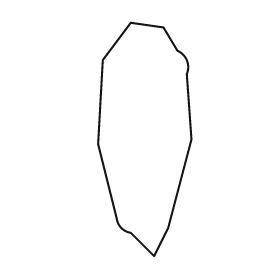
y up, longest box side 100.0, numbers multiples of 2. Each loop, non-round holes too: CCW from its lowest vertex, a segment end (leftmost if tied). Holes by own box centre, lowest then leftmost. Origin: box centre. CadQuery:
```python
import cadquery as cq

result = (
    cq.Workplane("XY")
    .moveTo(4.0, -50.0)
    .lineTo(10.0, -38.0)
    .lineTo(20.0, 0.0)
    .lineTo(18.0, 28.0)
    .threePointArc((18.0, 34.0), (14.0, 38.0))
    .lineTo(8.0, 48.0)
    .lineTo(-6.0, 50.0)
    .lineTo(-18.0, 34.0)
    .lineTo(-20.0, -2.0)
    .lineTo(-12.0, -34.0)
    .threePointArc((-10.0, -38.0), (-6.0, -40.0))
    .close()
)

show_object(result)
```